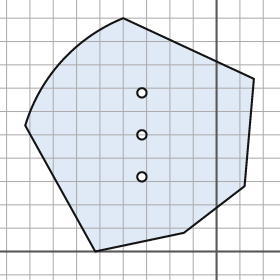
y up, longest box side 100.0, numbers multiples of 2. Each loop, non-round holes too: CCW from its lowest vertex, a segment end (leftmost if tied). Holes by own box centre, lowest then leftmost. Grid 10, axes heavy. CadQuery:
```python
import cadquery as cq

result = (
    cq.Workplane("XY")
    .moveTo(-52.0, 0.0)
    .lineTo(-14.0, 8.0)
    .lineTo(12.0, 28.0)
    .lineTo(16.0, 74.0)
    .lineTo(-40.0, 100.0)
    .threePointArc((-66.0, 82.0), (-82.0, 54.0))
    .close()
    .moveTo(-32.0, 32.0)
    .circle(2.0)
    .moveTo(-32.0, 50.0)
    .circle(2.0)
    .moveTo(-32.0, 68.0)
    .circle(2.0)
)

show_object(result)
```